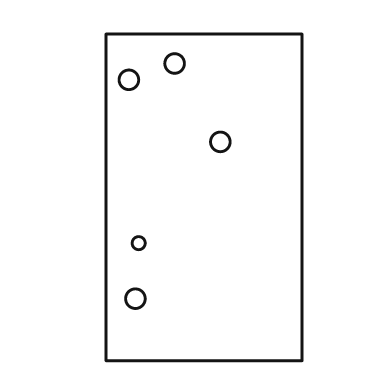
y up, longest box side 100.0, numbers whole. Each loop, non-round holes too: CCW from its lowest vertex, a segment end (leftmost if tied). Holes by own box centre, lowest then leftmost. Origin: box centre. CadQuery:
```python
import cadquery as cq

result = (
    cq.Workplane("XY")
    .moveTo(-30.0, -50.0)
    .lineTo(30.0, -50.0)
    .lineTo(30.0, 50.0)
    .lineTo(-30.0, 50.0)
    .close()
    .moveTo(-21.0, -31.0)
    .circle(3.0)
    .moveTo(-20.0, -14.0)
    .circle(2.0)
    .moveTo(5.0, 17.0)
    .circle(3.0)
    .moveTo(-23.0, 36.0)
    .circle(3.0)
    .moveTo(-9.0, 41.0)
    .circle(3.0)
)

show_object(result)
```